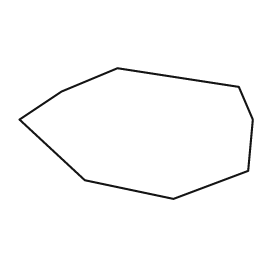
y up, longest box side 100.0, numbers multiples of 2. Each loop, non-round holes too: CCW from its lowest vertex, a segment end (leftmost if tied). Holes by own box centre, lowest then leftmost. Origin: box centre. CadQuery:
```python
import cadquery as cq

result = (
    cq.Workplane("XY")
    .moveTo(16.0, -28.0)
    .lineTo(48.0, -16.0)
    .lineTo(50.0, 6.0)
    .lineTo(44.0, 20.0)
    .lineTo(-8.0, 28.0)
    .lineTo(-32.0, 18.0)
    .lineTo(-50.0, 6.0)
    .lineTo(-22.0, -20.0)
    .close()
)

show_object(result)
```